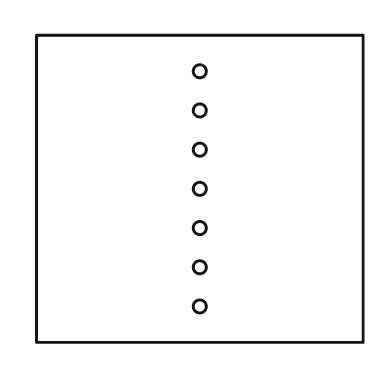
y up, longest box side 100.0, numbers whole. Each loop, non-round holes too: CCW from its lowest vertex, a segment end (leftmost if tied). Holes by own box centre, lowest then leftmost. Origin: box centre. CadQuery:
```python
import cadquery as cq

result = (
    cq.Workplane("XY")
    .moveTo(-50.0, -47.0)
    .lineTo(50.0, -47.0)
    .lineTo(50.0, 47.0)
    .lineTo(-50.0, 47.0)
    .close()
    .moveTo(0.0, -36.0)
    .circle(2.0)
    .moveTo(0.0, -24.0)
    .circle(2.0)
    .moveTo(0.0, -12.0)
    .circle(2.0)
    .moveTo(0.0, 0.0)
    .circle(2.0)
    .moveTo(0.0, 12.0)
    .circle(2.0)
    .moveTo(0.0, 24.0)
    .circle(2.0)
    .moveTo(0.0, 36.0)
    .circle(2.0)
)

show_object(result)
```